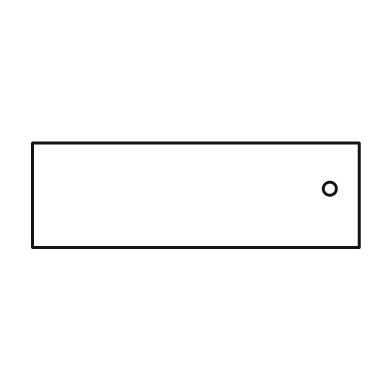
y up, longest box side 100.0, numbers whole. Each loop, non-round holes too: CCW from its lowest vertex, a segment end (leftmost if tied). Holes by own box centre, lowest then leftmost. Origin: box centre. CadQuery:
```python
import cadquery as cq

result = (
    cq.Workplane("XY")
    .moveTo(-50.0, -16.0)
    .lineTo(50.0, -16.0)
    .lineTo(50.0, 16.0)
    .lineTo(-50.0, 16.0)
    .close()
    .moveTo(41.0, 2.0)
    .circle(2.0)
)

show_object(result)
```